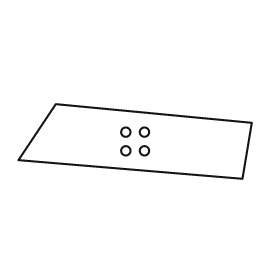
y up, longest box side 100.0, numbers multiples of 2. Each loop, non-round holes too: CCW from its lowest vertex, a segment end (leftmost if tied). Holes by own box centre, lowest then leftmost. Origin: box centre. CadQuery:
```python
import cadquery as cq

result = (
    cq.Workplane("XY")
    .moveTo(46.0, -16.0)
    .lineTo(50.0, 8.0)
    .lineTo(-34.0, 16.0)
    .lineTo(-50.0, -8.0)
    .close()
    .moveTo(-4.0, -4.0)
    .circle(2.0)
    .moveTo(4.0, -4.0)
    .circle(2.0)
    .moveTo(-4.0, 4.0)
    .circle(2.0)
    .moveTo(4.0, 4.0)
    .circle(2.0)
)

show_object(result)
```